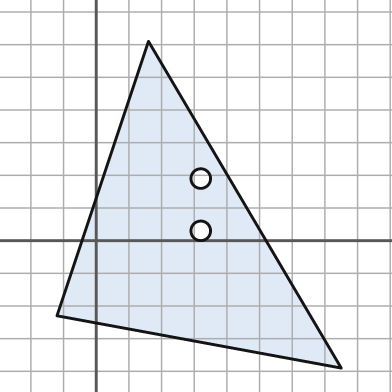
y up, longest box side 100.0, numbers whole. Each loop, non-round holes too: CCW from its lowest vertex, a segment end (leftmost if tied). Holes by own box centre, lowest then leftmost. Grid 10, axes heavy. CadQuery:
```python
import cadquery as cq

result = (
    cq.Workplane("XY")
    .moveTo(75.0, -39.0)
    .lineTo(16.0, 61.0)
    .lineTo(-12.0, -23.0)
    .close()
    .moveTo(32.0, 3.0)
    .circle(3.0)
    .moveTo(32.0, 19.0)
    .circle(3.0)
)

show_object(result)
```